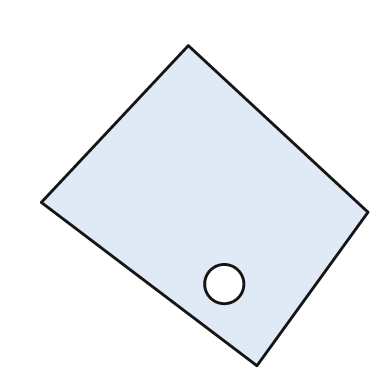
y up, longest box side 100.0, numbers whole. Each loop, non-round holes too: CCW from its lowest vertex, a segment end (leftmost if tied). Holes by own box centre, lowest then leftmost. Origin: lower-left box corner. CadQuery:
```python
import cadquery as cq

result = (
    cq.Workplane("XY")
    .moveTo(66.0, 0.0)
    .lineTo(100.0, 47.0)
    .lineTo(45.0, 98.0)
    .lineTo(0.0, 50.0)
    .close()
    .moveTo(56.0, 25.0)
    .circle(6.0)
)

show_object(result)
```